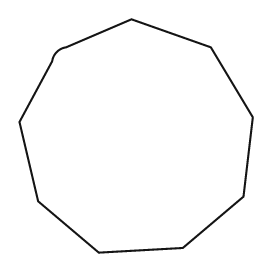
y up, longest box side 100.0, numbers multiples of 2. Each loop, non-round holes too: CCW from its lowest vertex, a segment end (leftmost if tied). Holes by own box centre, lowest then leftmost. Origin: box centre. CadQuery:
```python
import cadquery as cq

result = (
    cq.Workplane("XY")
    .moveTo(-16.0, -50.0)
    .lineTo(20.0, -48.0)
    .lineTo(46.0, -26.0)
    .lineTo(50.0, 8.0)
    .lineTo(32.0, 38.0)
    .lineTo(-2.0, 50.0)
    .lineTo(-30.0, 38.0)
    .threePointArc((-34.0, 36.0), (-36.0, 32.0))
    .lineTo(-50.0, 6.0)
    .lineTo(-42.0, -28.0)
    .close()
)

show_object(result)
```